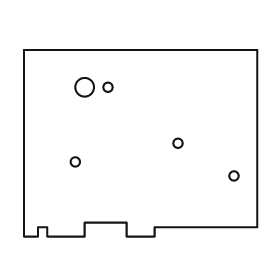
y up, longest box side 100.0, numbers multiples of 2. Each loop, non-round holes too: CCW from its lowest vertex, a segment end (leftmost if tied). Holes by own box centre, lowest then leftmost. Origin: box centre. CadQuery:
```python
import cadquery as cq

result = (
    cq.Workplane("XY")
    .moveTo(-50.0, -40.0)
    .lineTo(-44.0, -40.0)
    .lineTo(-44.0, -36.0)
    .lineTo(-40.0, -36.0)
    .lineTo(-40.0, -40.0)
    .lineTo(-24.0, -40.0)
    .lineTo(-24.0, -34.0)
    .lineTo(-6.0, -34.0)
    .lineTo(-6.0, -40.0)
    .lineTo(6.0, -40.0)
    .lineTo(6.0, -36.0)
    .lineTo(50.0, -36.0)
    .lineTo(50.0, 40.0)
    .lineTo(-50.0, 40.0)
    .close()
    .moveTo(40.0, -14.0)
    .circle(2.0)
    .moveTo(-28.0, -8.0)
    .circle(2.0)
    .moveTo(16.0, 0.0)
    .circle(2.0)
    .moveTo(-24.0, 24.0)
    .circle(4.0)
    .moveTo(-14.0, 24.0)
    .circle(2.0)
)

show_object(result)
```